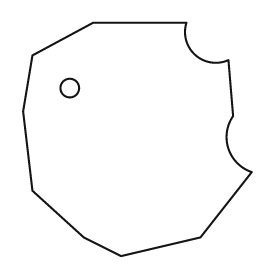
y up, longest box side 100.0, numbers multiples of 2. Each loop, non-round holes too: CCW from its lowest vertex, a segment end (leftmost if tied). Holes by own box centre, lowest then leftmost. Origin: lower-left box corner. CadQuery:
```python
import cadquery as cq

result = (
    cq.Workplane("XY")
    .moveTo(42.0, 0.0)
    .lineTo(76.0, 8.0)
    .lineTo(98.0, 36.0)
    .threePointArc((88.0, 46.0), (90.0, 60.0))
    .lineTo(88.0, 84.0)
    .threePointArc((74.0, 86.0), (70.0, 100.0))
    .lineTo(30.0, 100.0)
    .lineTo(4.0, 86.0)
    .lineTo(0.0, 62.0)
    .lineTo(4.0, 28.0)
    .lineTo(26.0, 8.0)
    .close()
    .moveTo(20.0, 72.0)
    .circle(4.0)
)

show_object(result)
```